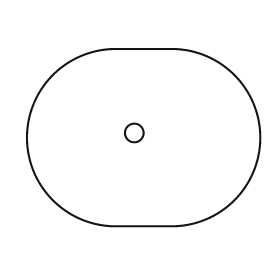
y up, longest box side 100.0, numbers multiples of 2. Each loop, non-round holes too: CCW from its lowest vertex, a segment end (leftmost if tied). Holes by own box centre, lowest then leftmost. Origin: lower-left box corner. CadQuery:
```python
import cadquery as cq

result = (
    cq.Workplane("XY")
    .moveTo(38.0, 0.0)
    .lineTo(62.0, 0.0)
    .threePointArc((100.0, 38.0), (62.0, 76.0))
    .lineTo(38.0, 76.0)
    .threePointArc((0.0, 38.0), (38.0, 0.0))
    .close()
    .moveTo(46.0, 40.0)
    .circle(4.0)
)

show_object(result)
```